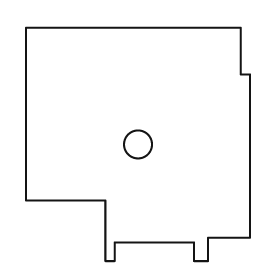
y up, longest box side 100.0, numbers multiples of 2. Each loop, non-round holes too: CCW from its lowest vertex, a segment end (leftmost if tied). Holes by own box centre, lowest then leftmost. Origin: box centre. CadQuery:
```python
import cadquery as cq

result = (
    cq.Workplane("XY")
    .moveTo(-14.0, -50.0)
    .lineTo(-10.0, -50.0)
    .lineTo(-10.0, -42.0)
    .lineTo(24.0, -42.0)
    .lineTo(24.0, -50.0)
    .lineTo(30.0, -50.0)
    .lineTo(30.0, -40.0)
    .lineTo(48.0, -40.0)
    .lineTo(48.0, 30.0)
    .lineTo(44.0, 30.0)
    .lineTo(44.0, 50.0)
    .lineTo(-48.0, 50.0)
    .lineTo(-48.0, -24.0)
    .lineTo(-14.0, -24.0)
    .close()
    .moveTo(0.0, 0.0)
    .circle(6.0)
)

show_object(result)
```